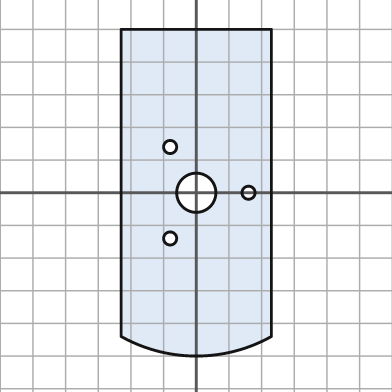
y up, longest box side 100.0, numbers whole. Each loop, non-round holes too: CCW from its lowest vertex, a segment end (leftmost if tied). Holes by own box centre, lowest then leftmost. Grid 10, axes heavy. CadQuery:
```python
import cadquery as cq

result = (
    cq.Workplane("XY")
    .moveTo(-23.0, -44.0)
    .threePointArc((0.0, -50.0), (23.0, -44.0))
    .lineTo(23.0, 50.0)
    .lineTo(-23.0, 50.0)
    .close()
    .moveTo(-8.0, -14.0)
    .circle(2.0)
    .moveTo(0.0, 0.0)
    .circle(6.0)
    .moveTo(16.0, 0.0)
    .circle(2.0)
    .moveTo(-8.0, 14.0)
    .circle(2.0)
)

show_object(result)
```